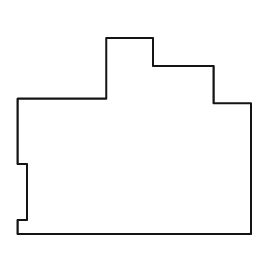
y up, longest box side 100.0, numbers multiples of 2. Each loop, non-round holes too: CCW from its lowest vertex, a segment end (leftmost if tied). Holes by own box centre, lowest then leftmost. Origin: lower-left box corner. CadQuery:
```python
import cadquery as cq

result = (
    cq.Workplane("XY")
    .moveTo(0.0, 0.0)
    .lineTo(100.0, 0.0)
    .lineTo(100.0, 56.0)
    .lineTo(84.0, 56.0)
    .lineTo(84.0, 72.0)
    .lineTo(58.0, 72.0)
    .lineTo(58.0, 84.0)
    .lineTo(38.0, 84.0)
    .lineTo(38.0, 58.0)
    .lineTo(0.0, 58.0)
    .lineTo(0.0, 30.0)
    .lineTo(4.0, 30.0)
    .lineTo(4.0, 6.0)
    .lineTo(0.0, 6.0)
    .close()
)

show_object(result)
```